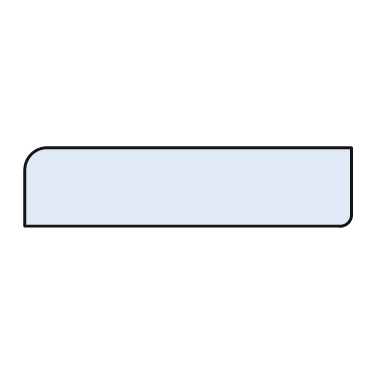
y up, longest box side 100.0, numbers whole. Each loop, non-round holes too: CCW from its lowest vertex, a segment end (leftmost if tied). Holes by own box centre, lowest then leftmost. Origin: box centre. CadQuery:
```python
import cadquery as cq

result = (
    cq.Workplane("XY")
    .moveTo(-50.0, -12.0)
    .lineTo(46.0, -12.0)
    .threePointArc((49.0, -11.0), (50.0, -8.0))
    .lineTo(50.0, 12.0)
    .lineTo(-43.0, 12.0)
    .threePointArc((-48.0, 10.0), (-50.0, 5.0))
    .close()
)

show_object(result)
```